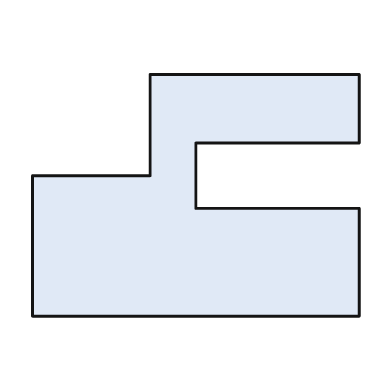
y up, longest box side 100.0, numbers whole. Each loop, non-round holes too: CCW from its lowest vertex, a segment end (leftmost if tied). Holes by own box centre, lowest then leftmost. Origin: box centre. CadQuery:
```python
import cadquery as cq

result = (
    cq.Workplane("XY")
    .moveTo(-50.0, -37.0)
    .lineTo(50.0, -37.0)
    .lineTo(50.0, -4.0)
    .lineTo(0.0, -4.0)
    .lineTo(0.0, 16.0)
    .lineTo(50.0, 16.0)
    .lineTo(50.0, 37.0)
    .lineTo(-14.0, 37.0)
    .lineTo(-14.0, 6.0)
    .lineTo(-50.0, 6.0)
    .close()
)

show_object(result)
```